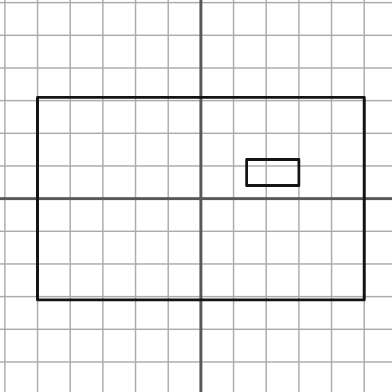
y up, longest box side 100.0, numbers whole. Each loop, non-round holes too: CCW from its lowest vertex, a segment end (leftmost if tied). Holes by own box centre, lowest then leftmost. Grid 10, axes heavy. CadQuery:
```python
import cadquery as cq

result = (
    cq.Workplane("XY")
    .moveTo(-50.0, -31.0)
    .lineTo(50.0, -31.0)
    .lineTo(50.0, 31.0)
    .lineTo(-50.0, 31.0)
    .close()
    .moveTo(14.0, 4.0)
    .lineTo(30.0, 4.0)
    .lineTo(30.0, 12.0)
    .lineTo(14.0, 12.0)
    .close()
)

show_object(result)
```